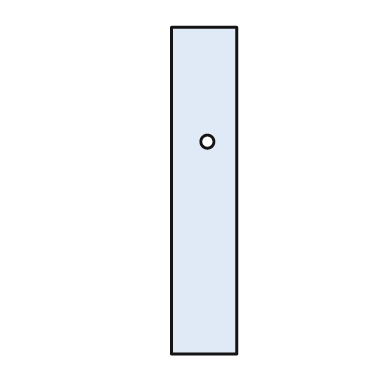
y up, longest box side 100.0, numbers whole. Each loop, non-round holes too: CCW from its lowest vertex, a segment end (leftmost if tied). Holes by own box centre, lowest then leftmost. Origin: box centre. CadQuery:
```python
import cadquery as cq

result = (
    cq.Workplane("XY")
    .moveTo(-10.0, -50.0)
    .lineTo(10.0, -50.0)
    .lineTo(10.0, 50.0)
    .lineTo(-10.0, 50.0)
    .close()
    .moveTo(1.0, 15.0)
    .circle(2.0)
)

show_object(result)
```